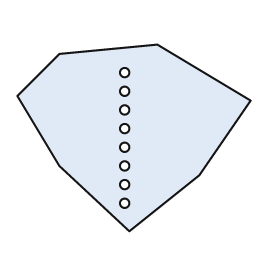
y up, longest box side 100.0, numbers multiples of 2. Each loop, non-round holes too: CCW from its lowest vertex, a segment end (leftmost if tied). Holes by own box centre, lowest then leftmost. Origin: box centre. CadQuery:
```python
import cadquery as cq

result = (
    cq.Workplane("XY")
    .moveTo(-2.0, -40.0)
    .lineTo(28.0, -16.0)
    .lineTo(50.0, 16.0)
    .lineTo(10.0, 40.0)
    .lineTo(-32.0, 36.0)
    .lineTo(-50.0, 18.0)
    .lineTo(-32.0, -12.0)
    .close()
    .moveTo(-4.0, -28.0)
    .circle(2.0)
    .moveTo(-4.0, -20.0)
    .circle(2.0)
    .moveTo(-4.0, -12.0)
    .circle(2.0)
    .moveTo(-4.0, -4.0)
    .circle(2.0)
    .moveTo(-4.0, 4.0)
    .circle(2.0)
    .moveTo(-4.0, 12.0)
    .circle(2.0)
    .moveTo(-4.0, 20.0)
    .circle(2.0)
    .moveTo(-4.0, 28.0)
    .circle(2.0)
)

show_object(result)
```